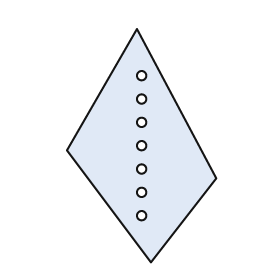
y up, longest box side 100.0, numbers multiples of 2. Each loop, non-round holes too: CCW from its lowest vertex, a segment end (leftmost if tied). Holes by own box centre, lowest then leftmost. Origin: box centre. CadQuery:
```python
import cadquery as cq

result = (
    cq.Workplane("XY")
    .moveTo(4.0, -50.0)
    .lineTo(32.0, -14.0)
    .lineTo(-2.0, 50.0)
    .lineTo(-32.0, -2.0)
    .close()
    .moveTo(0.0, -30.0)
    .circle(2.0)
    .moveTo(0.0, -20.0)
    .circle(2.0)
    .moveTo(0.0, -10.0)
    .circle(2.0)
    .moveTo(0.0, 0.0)
    .circle(2.0)
    .moveTo(0.0, 10.0)
    .circle(2.0)
    .moveTo(0.0, 20.0)
    .circle(2.0)
    .moveTo(0.0, 30.0)
    .circle(2.0)
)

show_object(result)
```